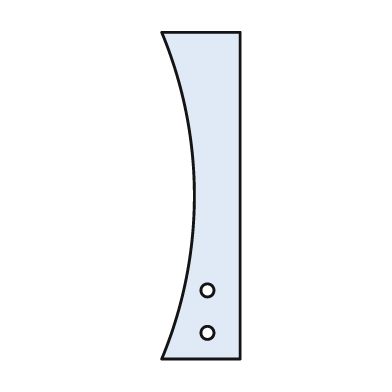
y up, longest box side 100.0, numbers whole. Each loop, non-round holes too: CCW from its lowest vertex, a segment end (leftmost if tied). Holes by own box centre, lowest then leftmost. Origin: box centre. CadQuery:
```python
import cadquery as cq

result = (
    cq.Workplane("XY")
    .moveTo(-12.0, -50.0)
    .lineTo(12.0, -50.0)
    .lineTo(12.0, 50.0)
    .lineTo(-12.0, 50.0)
    .threePointArc((-2.0, 0.0), (-12.0, -50.0))
    .close()
    .moveTo(2.0, -42.0)
    .circle(2.0)
    .moveTo(2.0, -29.0)
    .circle(2.0)
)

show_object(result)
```